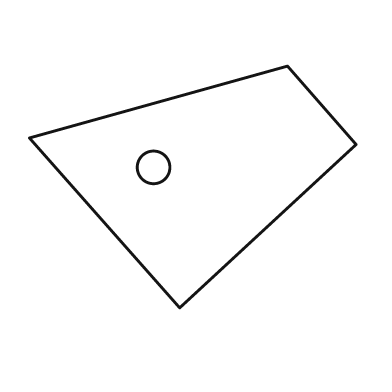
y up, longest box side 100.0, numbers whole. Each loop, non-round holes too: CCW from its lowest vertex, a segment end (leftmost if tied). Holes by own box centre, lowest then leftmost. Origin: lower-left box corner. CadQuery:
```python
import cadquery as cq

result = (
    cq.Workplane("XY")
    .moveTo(46.0, 0.0)
    .lineTo(100.0, 50.0)
    .lineTo(79.0, 74.0)
    .lineTo(0.0, 52.0)
    .close()
    .moveTo(38.0, 43.0)
    .circle(5.0)
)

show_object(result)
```